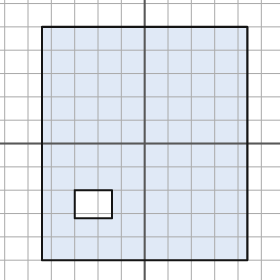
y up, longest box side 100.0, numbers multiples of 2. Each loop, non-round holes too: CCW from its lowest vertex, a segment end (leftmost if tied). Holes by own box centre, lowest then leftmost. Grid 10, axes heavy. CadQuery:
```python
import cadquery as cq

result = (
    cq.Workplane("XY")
    .moveTo(-44.0, -50.0)
    .lineTo(44.0, -50.0)
    .lineTo(44.0, 50.0)
    .lineTo(-44.0, 50.0)
    .close()
    .moveTo(-30.0, -32.0)
    .lineTo(-14.0, -32.0)
    .lineTo(-14.0, -20.0)
    .lineTo(-30.0, -20.0)
    .close()
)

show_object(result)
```